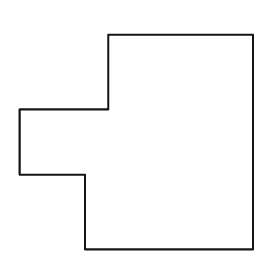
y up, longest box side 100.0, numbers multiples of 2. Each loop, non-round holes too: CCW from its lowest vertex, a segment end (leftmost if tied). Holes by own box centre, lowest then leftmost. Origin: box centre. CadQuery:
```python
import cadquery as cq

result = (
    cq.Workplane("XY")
    .moveTo(-22.0, -46.0)
    .lineTo(50.0, -46.0)
    .lineTo(50.0, 46.0)
    .lineTo(-12.0, 46.0)
    .lineTo(-12.0, 14.0)
    .lineTo(-50.0, 14.0)
    .lineTo(-50.0, -14.0)
    .lineTo(-22.0, -14.0)
    .close()
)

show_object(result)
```